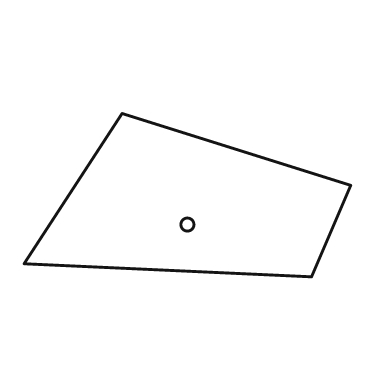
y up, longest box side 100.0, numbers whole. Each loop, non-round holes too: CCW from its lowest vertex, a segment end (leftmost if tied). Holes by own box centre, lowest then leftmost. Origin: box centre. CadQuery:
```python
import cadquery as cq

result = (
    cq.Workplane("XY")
    .moveTo(38.0, -25.0)
    .lineTo(50.0, 3.0)
    .lineTo(-20.0, 25.0)
    .lineTo(-50.0, -21.0)
    .close()
    .moveTo(0.0, -9.0)
    .circle(2.0)
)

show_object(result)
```